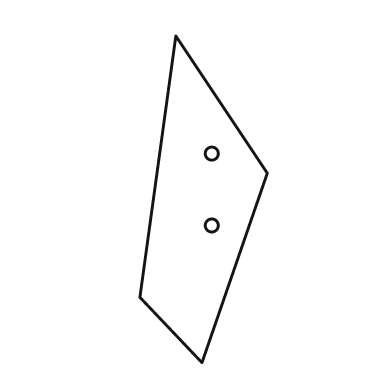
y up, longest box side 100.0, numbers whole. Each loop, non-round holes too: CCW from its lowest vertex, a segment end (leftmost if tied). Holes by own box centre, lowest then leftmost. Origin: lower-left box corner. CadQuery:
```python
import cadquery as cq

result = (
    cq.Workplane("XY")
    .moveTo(19.0, 0.0)
    .lineTo(39.0, 58.0)
    .lineTo(11.0, 100.0)
    .lineTo(0.0, 20.0)
    .close()
    .moveTo(22.0, 42.0)
    .circle(2.0)
    .moveTo(22.0, 64.0)
    .circle(2.0)
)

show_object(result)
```